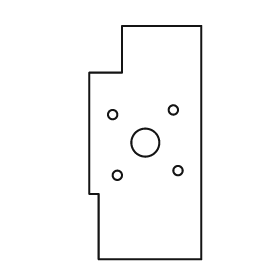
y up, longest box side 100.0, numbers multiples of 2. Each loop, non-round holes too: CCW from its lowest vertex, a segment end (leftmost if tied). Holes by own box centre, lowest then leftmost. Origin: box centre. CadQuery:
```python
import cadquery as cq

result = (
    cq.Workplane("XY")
    .moveTo(-20.0, -50.0)
    .lineTo(24.0, -50.0)
    .lineTo(24.0, 50.0)
    .lineTo(-10.0, 50.0)
    .lineTo(-10.0, 30.0)
    .lineTo(-24.0, 30.0)
    .lineTo(-24.0, -22.0)
    .lineTo(-20.0, -22.0)
    .close()
    .moveTo(-12.0, -14.0)
    .circle(2.0)
    .moveTo(14.0, -12.0)
    .circle(2.0)
    .moveTo(0.0, 0.0)
    .circle(6.0)
    .moveTo(-14.0, 12.0)
    .circle(2.0)
    .moveTo(12.0, 14.0)
    .circle(2.0)
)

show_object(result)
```